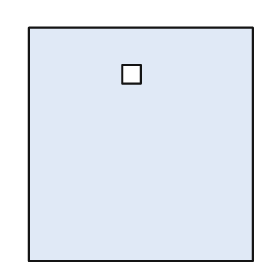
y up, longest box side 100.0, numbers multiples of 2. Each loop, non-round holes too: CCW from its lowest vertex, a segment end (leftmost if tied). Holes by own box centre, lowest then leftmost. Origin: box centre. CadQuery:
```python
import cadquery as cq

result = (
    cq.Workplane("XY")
    .moveTo(-48.0, -50.0)
    .lineTo(48.0, -50.0)
    .lineTo(48.0, 50.0)
    .lineTo(-48.0, 50.0)
    .close()
    .moveTo(-8.0, 26.0)
    .lineTo(0.0, 26.0)
    .lineTo(0.0, 34.0)
    .lineTo(-8.0, 34.0)
    .close()
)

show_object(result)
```